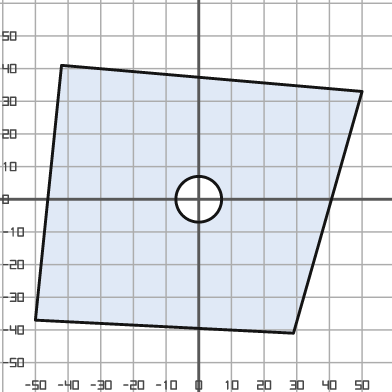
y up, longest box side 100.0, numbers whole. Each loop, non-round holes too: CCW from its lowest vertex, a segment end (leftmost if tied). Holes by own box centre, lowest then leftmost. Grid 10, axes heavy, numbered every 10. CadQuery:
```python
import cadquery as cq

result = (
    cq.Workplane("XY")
    .moveTo(29.0, -41.0)
    .lineTo(50.0, 33.0)
    .lineTo(-42.0, 41.0)
    .lineTo(-50.0, -37.0)
    .close()
    .moveTo(0.0, 0.0)
    .circle(7.0)
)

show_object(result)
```